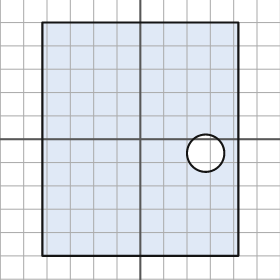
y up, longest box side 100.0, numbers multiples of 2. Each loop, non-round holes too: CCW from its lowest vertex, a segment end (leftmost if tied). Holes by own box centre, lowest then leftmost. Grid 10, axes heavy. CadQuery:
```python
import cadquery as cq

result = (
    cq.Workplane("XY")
    .moveTo(-42.0, -50.0)
    .lineTo(42.0, -50.0)
    .lineTo(42.0, 50.0)
    .lineTo(-42.0, 50.0)
    .close()
    .moveTo(28.0, -6.0)
    .circle(8.0)
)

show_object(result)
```